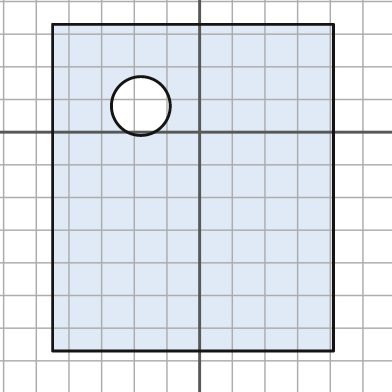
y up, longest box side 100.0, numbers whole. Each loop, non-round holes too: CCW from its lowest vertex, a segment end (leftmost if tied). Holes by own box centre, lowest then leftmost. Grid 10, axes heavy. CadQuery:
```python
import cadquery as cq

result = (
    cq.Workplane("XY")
    .moveTo(-45.0, -67.0)
    .lineTo(41.0, -67.0)
    .lineTo(41.0, 33.0)
    .lineTo(-45.0, 33.0)
    .close()
    .moveTo(-18.0, 8.0)
    .circle(9.0)
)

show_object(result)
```